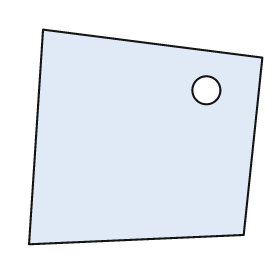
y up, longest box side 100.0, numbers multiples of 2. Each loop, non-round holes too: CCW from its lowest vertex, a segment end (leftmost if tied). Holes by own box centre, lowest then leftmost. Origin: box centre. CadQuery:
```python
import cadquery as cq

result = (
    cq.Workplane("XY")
    .moveTo(-50.0, -46.0)
    .lineTo(42.0, -42.0)
    .lineTo(50.0, 34.0)
    .lineTo(-44.0, 46.0)
    .close()
    .moveTo(26.0, 20.0)
    .circle(6.0)
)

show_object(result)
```